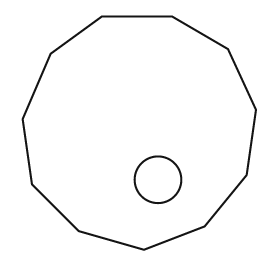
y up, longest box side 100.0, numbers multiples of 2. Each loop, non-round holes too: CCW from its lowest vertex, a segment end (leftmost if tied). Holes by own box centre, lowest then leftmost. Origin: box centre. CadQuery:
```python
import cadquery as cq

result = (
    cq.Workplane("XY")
    .moveTo(2.0, -50.0)
    .lineTo(28.0, -40.0)
    .lineTo(46.0, -18.0)
    .lineTo(50.0, 10.0)
    .lineTo(38.0, 36.0)
    .lineTo(14.0, 50.0)
    .lineTo(-16.0, 50.0)
    .lineTo(-38.0, 34.0)
    .lineTo(-50.0, 6.0)
    .lineTo(-46.0, -22.0)
    .lineTo(-26.0, -42.0)
    .close()
    .moveTo(8.0, -20.0)
    .circle(10.0)
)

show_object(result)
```